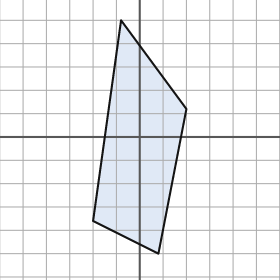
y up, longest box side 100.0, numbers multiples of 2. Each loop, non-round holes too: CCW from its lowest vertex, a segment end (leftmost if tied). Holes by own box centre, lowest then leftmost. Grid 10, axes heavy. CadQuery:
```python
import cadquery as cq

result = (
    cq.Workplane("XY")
    .moveTo(8.0, -50.0)
    .lineTo(20.0, 12.0)
    .lineTo(-8.0, 50.0)
    .lineTo(-20.0, -36.0)
    .close()
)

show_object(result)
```